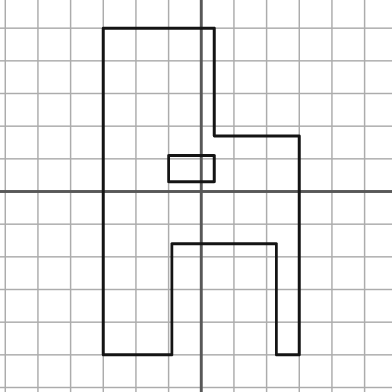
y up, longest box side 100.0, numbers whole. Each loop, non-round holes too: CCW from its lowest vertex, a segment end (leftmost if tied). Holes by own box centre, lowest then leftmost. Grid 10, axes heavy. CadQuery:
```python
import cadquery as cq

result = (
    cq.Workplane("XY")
    .moveTo(-30.0, -50.0)
    .lineTo(-9.0, -50.0)
    .lineTo(-9.0, -16.0)
    .lineTo(23.0, -16.0)
    .lineTo(23.0, -50.0)
    .lineTo(30.0, -50.0)
    .lineTo(30.0, 17.0)
    .lineTo(4.0, 17.0)
    .lineTo(4.0, 50.0)
    .lineTo(-30.0, 50.0)
    .close()
    .moveTo(-10.0, 3.0)
    .lineTo(4.0, 3.0)
    .lineTo(4.0, 11.0)
    .lineTo(-10.0, 11.0)
    .close()
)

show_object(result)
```